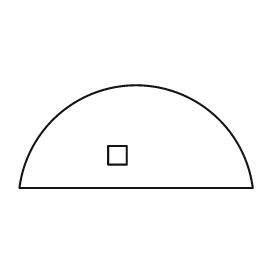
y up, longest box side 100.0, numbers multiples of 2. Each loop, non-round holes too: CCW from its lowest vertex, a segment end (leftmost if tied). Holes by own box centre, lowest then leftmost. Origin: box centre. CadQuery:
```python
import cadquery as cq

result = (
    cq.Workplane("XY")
    .moveTo(-50.0, -22.0)
    .lineTo(50.0, -22.0)
    .threePointArc((0.0, 22.0), (-50.0, -22.0))
    .close()
    .moveTo(-12.0, -12.0)
    .lineTo(-4.0, -12.0)
    .lineTo(-4.0, -4.0)
    .lineTo(-12.0, -4.0)
    .close()
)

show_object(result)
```